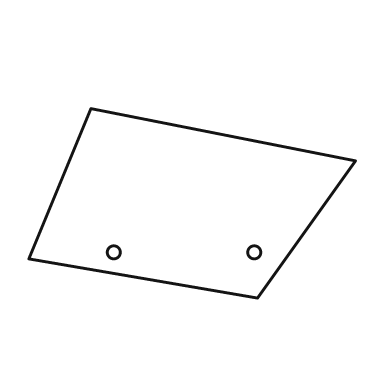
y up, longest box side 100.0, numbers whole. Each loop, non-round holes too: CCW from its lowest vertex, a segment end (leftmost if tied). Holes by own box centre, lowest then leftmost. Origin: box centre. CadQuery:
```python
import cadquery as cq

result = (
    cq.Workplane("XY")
    .moveTo(20.0, -29.0)
    .lineTo(50.0, 13.0)
    .lineTo(-31.0, 29.0)
    .lineTo(-50.0, -17.0)
    .close()
    .moveTo(-24.0, -15.0)
    .circle(2.0)
    .moveTo(19.0, -15.0)
    .circle(2.0)
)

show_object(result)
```